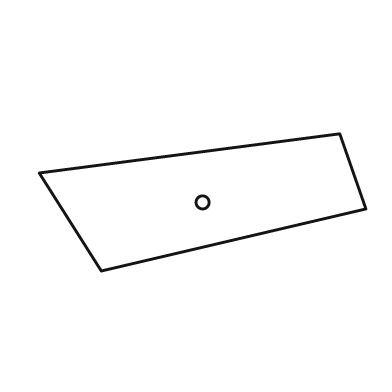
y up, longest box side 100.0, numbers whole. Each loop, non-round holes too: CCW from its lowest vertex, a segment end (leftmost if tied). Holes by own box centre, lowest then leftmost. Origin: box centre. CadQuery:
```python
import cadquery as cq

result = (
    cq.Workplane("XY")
    .moveTo(-31.0, -21.0)
    .lineTo(50.0, -2.0)
    .lineTo(42.0, 21.0)
    .lineTo(-50.0, 9.0)
    .close()
    .moveTo(0.0, 0.0)
    .circle(2.0)
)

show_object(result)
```